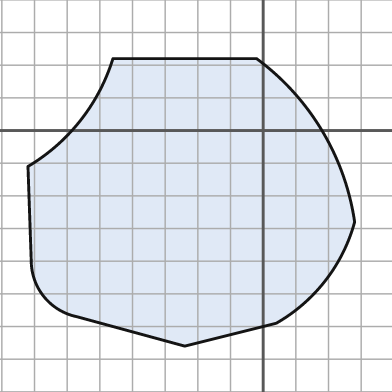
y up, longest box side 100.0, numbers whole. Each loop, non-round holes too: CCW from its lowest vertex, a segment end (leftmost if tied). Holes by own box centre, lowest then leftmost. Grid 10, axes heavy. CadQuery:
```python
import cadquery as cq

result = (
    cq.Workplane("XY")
    .moveTo(-24.0, -66.0)
    .lineTo(4.0, -59.0)
    .threePointArc((19.0, -46.0), (28.0, -28.0))
    .threePointArc((18.0, 0.0), (-2.0, 22.0))
    .lineTo(-46.0, 22.0)
    .threePointArc((-56.0, 3.0), (-72.0, -11.0))
    .lineTo(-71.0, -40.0)
    .threePointArc((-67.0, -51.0), (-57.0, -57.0))
    .close()
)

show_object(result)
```